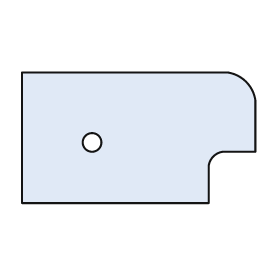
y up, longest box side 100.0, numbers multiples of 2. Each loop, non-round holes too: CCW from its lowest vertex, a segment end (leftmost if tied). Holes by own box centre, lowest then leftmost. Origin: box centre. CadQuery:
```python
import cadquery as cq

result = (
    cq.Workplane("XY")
    .moveTo(-50.0, -28.0)
    .lineTo(30.0, -28.0)
    .lineTo(30.0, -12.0)
    .threePointArc((32.0, -8.0), (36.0, -6.0))
    .lineTo(50.0, -6.0)
    .lineTo(50.0, 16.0)
    .threePointArc((46.0, 24.0), (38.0, 28.0))
    .lineTo(-50.0, 28.0)
    .close()
    .moveTo(-20.0, -2.0)
    .circle(4.0)
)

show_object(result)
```